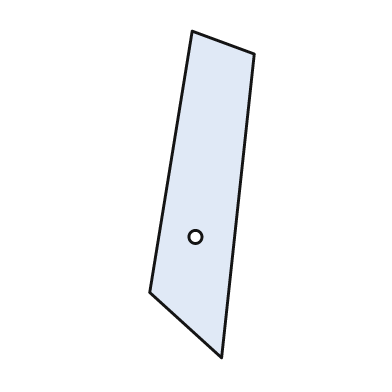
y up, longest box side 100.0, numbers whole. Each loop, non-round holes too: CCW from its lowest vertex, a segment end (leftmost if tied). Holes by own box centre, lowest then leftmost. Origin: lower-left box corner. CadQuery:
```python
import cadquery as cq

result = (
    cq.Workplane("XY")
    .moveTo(22.0, 0.0)
    .lineTo(32.0, 93.0)
    .lineTo(13.0, 100.0)
    .lineTo(0.0, 20.0)
    .close()
    .moveTo(14.0, 37.0)
    .circle(2.0)
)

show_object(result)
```